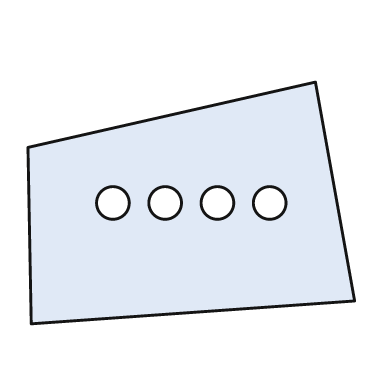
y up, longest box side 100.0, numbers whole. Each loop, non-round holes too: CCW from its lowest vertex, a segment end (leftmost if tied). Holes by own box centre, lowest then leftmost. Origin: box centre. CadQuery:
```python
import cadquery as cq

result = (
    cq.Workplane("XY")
    .moveTo(-49.0, -37.0)
    .lineTo(50.0, -30.0)
    .lineTo(38.0, 37.0)
    .lineTo(-50.0, 17.0)
    .close()
    .moveTo(-24.0, 0.0)
    .circle(5.0)
    .moveTo(-8.0, 0.0)
    .circle(5.0)
    .moveTo(8.0, 0.0)
    .circle(5.0)
    .moveTo(24.0, 0.0)
    .circle(5.0)
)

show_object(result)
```